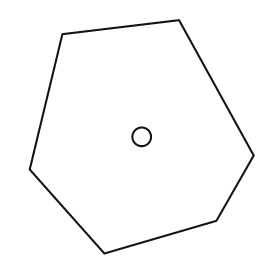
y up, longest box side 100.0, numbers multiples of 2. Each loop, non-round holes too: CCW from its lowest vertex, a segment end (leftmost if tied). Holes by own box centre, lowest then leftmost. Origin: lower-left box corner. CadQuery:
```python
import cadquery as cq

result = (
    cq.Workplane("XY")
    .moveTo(32.0, 0.0)
    .lineTo(80.0, 14.0)
    .lineTo(96.0, 42.0)
    .lineTo(64.0, 100.0)
    .lineTo(14.0, 94.0)
    .lineTo(0.0, 36.0)
    .close()
    .moveTo(48.0, 50.0)
    .circle(4.0)
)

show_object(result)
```